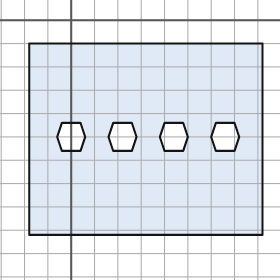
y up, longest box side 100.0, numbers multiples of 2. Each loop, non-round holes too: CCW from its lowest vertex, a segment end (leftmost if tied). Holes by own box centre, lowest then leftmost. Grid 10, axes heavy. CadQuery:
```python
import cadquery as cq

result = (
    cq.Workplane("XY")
    .moveTo(-18.0, -92.0)
    .lineTo(82.0, -92.0)
    .lineTo(82.0, -10.0)
    .lineTo(-18.0, -10.0)
    .close()
    .moveTo(-4.0, -56.0)
    .lineTo(4.0, -56.0)
    .lineTo(6.0, -50.0)
    .lineTo(4.0, -44.0)
    .lineTo(-4.0, -44.0)
    .lineTo(-6.0, -50.0)
    .close()
    .moveTo(18.0, -56.0)
    .lineTo(26.0, -56.0)
    .lineTo(28.0, -50.0)
    .lineTo(26.0, -44.0)
    .lineTo(18.0, -44.0)
    .lineTo(16.0, -50.0)
    .close()
    .moveTo(40.0, -56.0)
    .lineTo(48.0, -56.0)
    .lineTo(50.0, -50.0)
    .lineTo(48.0, -44.0)
    .lineTo(40.0, -44.0)
    .lineTo(38.0, -50.0)
    .close()
    .moveTo(62.0, -56.0)
    .lineTo(70.0, -56.0)
    .lineTo(72.0, -50.0)
    .lineTo(70.0, -44.0)
    .lineTo(62.0, -44.0)
    .lineTo(60.0, -50.0)
    .close()
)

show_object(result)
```